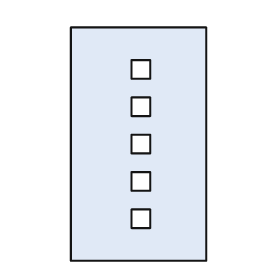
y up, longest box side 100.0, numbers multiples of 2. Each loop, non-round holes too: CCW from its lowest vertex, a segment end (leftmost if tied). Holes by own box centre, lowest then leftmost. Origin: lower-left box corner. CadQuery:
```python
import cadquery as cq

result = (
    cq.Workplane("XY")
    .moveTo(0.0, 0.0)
    .lineTo(58.0, 0.0)
    .lineTo(58.0, 100.0)
    .lineTo(0.0, 100.0)
    .close()
    .moveTo(26.0, 14.0)
    .lineTo(34.0, 14.0)
    .lineTo(34.0, 22.0)
    .lineTo(26.0, 22.0)
    .close()
    .moveTo(26.0, 30.0)
    .lineTo(34.0, 30.0)
    .lineTo(34.0, 38.0)
    .lineTo(26.0, 38.0)
    .close()
    .moveTo(26.0, 46.0)
    .lineTo(34.0, 46.0)
    .lineTo(34.0, 54.0)
    .lineTo(26.0, 54.0)
    .close()
    .moveTo(26.0, 62.0)
    .lineTo(34.0, 62.0)
    .lineTo(34.0, 70.0)
    .lineTo(26.0, 70.0)
    .close()
    .moveTo(26.0, 78.0)
    .lineTo(34.0, 78.0)
    .lineTo(34.0, 86.0)
    .lineTo(26.0, 86.0)
    .close()
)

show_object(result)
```